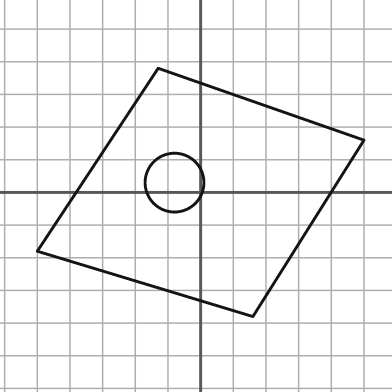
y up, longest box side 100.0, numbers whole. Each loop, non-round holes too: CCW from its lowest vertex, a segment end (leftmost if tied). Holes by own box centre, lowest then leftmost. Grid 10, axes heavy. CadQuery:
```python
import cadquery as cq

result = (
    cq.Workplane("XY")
    .moveTo(16.0, -38.0)
    .lineTo(50.0, 16.0)
    .lineTo(-13.0, 38.0)
    .lineTo(-50.0, -18.0)
    .close()
    .moveTo(-8.0, 3.0)
    .circle(9.0)
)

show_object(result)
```